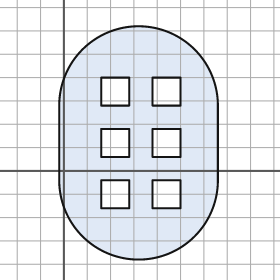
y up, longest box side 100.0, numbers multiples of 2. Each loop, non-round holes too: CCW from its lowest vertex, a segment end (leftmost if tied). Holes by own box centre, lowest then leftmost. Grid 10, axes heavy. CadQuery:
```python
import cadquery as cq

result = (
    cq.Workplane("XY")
    .moveTo(-2.0, -4.0)
    .threePointArc((32.0, -38.0), (66.0, -4.0))
    .lineTo(66.0, 28.0)
    .threePointArc((32.0, 62.0), (-2.0, 28.0))
    .close()
    .moveTo(16.0, -16.0)
    .lineTo(28.0, -16.0)
    .lineTo(28.0, -4.0)
    .lineTo(16.0, -4.0)
    .close()
    .moveTo(38.0, -16.0)
    .lineTo(50.0, -16.0)
    .lineTo(50.0, -4.0)
    .lineTo(38.0, -4.0)
    .close()
    .moveTo(16.0, 6.0)
    .lineTo(28.0, 6.0)
    .lineTo(28.0, 18.0)
    .lineTo(16.0, 18.0)
    .close()
    .moveTo(38.0, 6.0)
    .lineTo(50.0, 6.0)
    .lineTo(50.0, 18.0)
    .lineTo(38.0, 18.0)
    .close()
    .moveTo(16.0, 28.0)
    .lineTo(28.0, 28.0)
    .lineTo(28.0, 40.0)
    .lineTo(16.0, 40.0)
    .close()
    .moveTo(38.0, 28.0)
    .lineTo(50.0, 28.0)
    .lineTo(50.0, 40.0)
    .lineTo(38.0, 40.0)
    .close()
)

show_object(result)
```